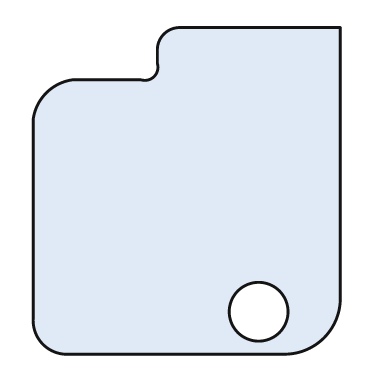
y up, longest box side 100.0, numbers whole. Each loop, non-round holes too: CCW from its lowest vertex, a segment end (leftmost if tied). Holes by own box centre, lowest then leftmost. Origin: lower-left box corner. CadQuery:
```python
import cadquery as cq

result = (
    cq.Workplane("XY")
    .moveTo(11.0, 0.0)
    .lineTo(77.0, 0.0)
    .threePointArc((89.0, 5.0), (94.0, 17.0))
    .lineTo(94.0, 100.0)
    .lineTo(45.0, 100.0)
    .threePointArc((40.0, 98.0), (38.0, 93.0))
    .lineTo(38.0, 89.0)
    .threePointArc((37.0, 85.0), (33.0, 84.0))
    .lineTo(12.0, 84.0)
    .threePointArc((4.0, 80.0), (0.0, 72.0))
    .lineTo(0.0, 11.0)
    .threePointArc((3.0, 3.0), (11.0, 0.0))
    .close()
    .moveTo(69.0, 13.0)
    .circle(9.0)
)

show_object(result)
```